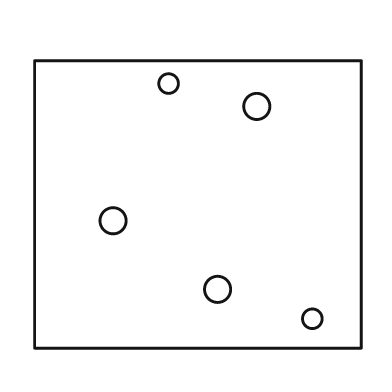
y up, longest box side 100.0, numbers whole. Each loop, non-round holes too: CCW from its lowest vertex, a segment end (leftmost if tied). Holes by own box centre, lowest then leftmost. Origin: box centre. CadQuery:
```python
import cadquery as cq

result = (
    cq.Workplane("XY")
    .moveTo(-50.0, -44.0)
    .lineTo(50.0, -44.0)
    .lineTo(50.0, 44.0)
    .lineTo(-50.0, 44.0)
    .close()
    .moveTo(35.0, -35.0)
    .circle(3.0)
    .moveTo(6.0, -26.0)
    .circle(4.0)
    .moveTo(-26.0, -5.0)
    .circle(4.0)
    .moveTo(18.0, 30.0)
    .circle(4.0)
    .moveTo(-9.0, 37.0)
    .circle(3.0)
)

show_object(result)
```